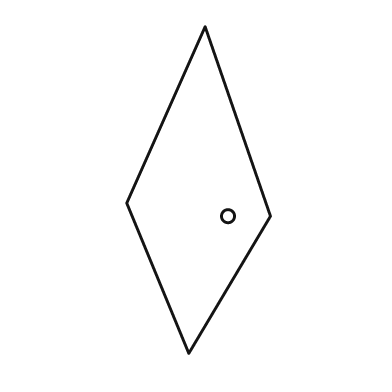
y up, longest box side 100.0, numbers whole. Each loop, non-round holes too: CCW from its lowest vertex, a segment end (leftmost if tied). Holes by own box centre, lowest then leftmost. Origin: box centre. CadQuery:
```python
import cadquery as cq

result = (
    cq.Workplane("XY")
    .moveTo(-3.0, -50.0)
    .lineTo(22.0, -8.0)
    .lineTo(2.0, 50.0)
    .lineTo(-22.0, -4.0)
    .close()
    .moveTo(9.0, -8.0)
    .circle(2.0)
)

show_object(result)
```